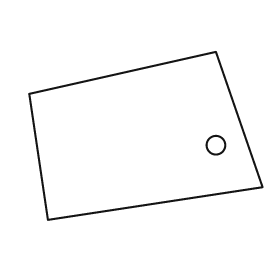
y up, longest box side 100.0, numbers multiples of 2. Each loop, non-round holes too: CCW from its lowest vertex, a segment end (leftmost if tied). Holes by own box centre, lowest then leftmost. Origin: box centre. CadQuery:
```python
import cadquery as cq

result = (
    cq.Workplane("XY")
    .moveTo(-42.0, -36.0)
    .lineTo(50.0, -22.0)
    .lineTo(30.0, 36.0)
    .lineTo(-50.0, 18.0)
    .close()
    .moveTo(30.0, -4.0)
    .circle(4.0)
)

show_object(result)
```